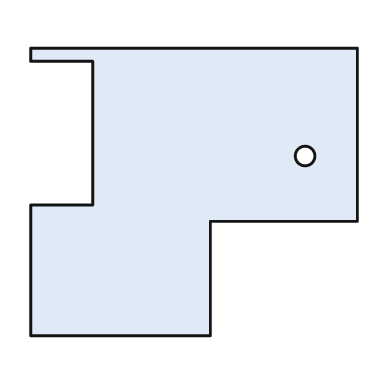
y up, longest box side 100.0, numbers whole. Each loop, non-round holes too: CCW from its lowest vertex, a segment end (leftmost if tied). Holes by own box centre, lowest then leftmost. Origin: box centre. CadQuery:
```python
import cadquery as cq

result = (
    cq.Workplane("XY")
    .moveTo(-50.0, -44.0)
    .lineTo(5.0, -44.0)
    .lineTo(5.0, -9.0)
    .lineTo(50.0, -9.0)
    .lineTo(50.0, 44.0)
    .lineTo(-50.0, 44.0)
    .lineTo(-50.0, 40.0)
    .lineTo(-31.0, 40.0)
    .lineTo(-31.0, -4.0)
    .lineTo(-50.0, -4.0)
    .close()
    .moveTo(34.0, 11.0)
    .circle(3.0)
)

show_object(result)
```